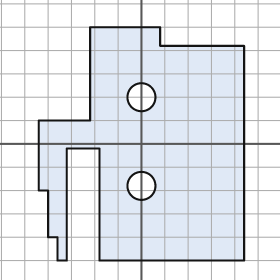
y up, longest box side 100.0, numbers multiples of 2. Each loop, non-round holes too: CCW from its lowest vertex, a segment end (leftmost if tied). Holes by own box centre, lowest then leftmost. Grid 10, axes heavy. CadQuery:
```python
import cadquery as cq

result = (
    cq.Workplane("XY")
    .moveTo(-36.0, -50.0)
    .lineTo(-32.0, -50.0)
    .lineTo(-32.0, -2.0)
    .lineTo(-18.0, -2.0)
    .lineTo(-18.0, -50.0)
    .lineTo(44.0, -50.0)
    .lineTo(44.0, 42.0)
    .lineTo(8.0, 42.0)
    .lineTo(8.0, 50.0)
    .lineTo(-22.0, 50.0)
    .lineTo(-22.0, 10.0)
    .lineTo(-44.0, 10.0)
    .lineTo(-44.0, -20.0)
    .lineTo(-40.0, -20.0)
    .lineTo(-40.0, -40.0)
    .lineTo(-36.0, -40.0)
    .close()
    .moveTo(0.0, -18.0)
    .circle(6.0)
    .moveTo(0.0, 20.0)
    .circle(6.0)
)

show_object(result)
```